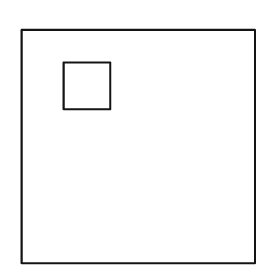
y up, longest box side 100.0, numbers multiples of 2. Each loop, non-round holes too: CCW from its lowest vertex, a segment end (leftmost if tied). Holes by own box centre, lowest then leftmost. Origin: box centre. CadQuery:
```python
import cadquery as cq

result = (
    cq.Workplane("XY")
    .moveTo(-50.0, -50.0)
    .lineTo(50.0, -50.0)
    .lineTo(50.0, 50.0)
    .lineTo(-50.0, 50.0)
    .close()
    .moveTo(-32.0, 16.0)
    .lineTo(-12.0, 16.0)
    .lineTo(-12.0, 36.0)
    .lineTo(-32.0, 36.0)
    .close()
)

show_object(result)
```